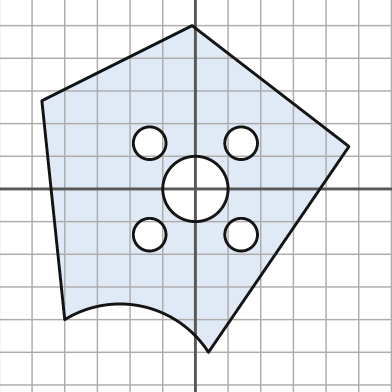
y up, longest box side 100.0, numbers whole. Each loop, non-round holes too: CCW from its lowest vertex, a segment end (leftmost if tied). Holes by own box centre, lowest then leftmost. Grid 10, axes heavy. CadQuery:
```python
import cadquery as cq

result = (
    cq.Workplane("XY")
    .moveTo(4.0, -50.0)
    .lineTo(47.0, 13.0)
    .lineTo(-1.0, 50.0)
    .lineTo(-47.0, 27.0)
    .lineTo(-40.0, -40.0)
    .threePointArc((-16.0, -36.0), (4.0, -50.0))
    .close()
    .moveTo(-14.0, -14.0)
    .circle(5.0)
    .moveTo(14.0, -14.0)
    .circle(5.0)
    .moveTo(0.0, 0.0)
    .circle(10.0)
    .moveTo(-14.0, 14.0)
    .circle(5.0)
    .moveTo(14.0, 14.0)
    .circle(5.0)
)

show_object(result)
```